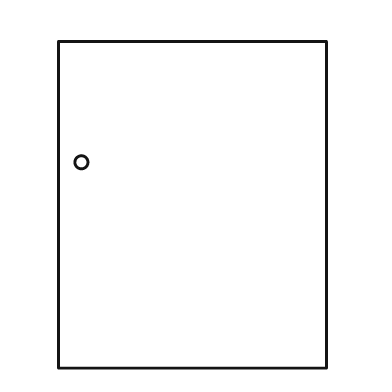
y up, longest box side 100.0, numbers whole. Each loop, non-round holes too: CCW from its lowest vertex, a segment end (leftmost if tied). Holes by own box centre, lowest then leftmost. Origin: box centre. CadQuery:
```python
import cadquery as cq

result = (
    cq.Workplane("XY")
    .moveTo(-41.0, -50.0)
    .lineTo(41.0, -50.0)
    .lineTo(41.0, 50.0)
    .lineTo(-41.0, 50.0)
    .close()
    .moveTo(-34.0, 13.0)
    .circle(2.0)
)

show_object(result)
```